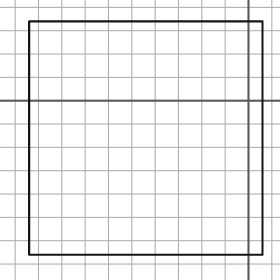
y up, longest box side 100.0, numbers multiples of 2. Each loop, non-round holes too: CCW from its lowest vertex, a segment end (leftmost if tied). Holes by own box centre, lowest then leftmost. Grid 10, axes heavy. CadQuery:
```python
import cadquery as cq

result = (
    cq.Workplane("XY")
    .moveTo(-94.0, -66.0)
    .lineTo(6.0, -66.0)
    .lineTo(6.0, 34.0)
    .lineTo(-94.0, 34.0)
    .close()
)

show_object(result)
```